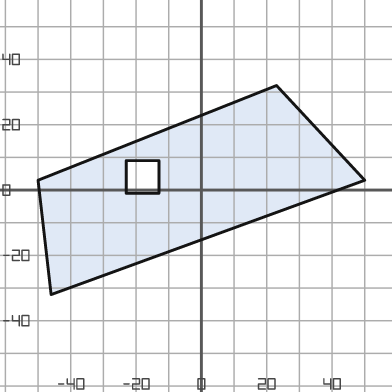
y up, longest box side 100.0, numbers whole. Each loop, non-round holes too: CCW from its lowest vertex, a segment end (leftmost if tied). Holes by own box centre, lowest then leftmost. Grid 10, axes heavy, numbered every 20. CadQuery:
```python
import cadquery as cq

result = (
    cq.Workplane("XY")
    .moveTo(-46.0, -32.0)
    .lineTo(50.0, 3.0)
    .lineTo(23.0, 32.0)
    .lineTo(-50.0, 3.0)
    .close()
    .moveTo(-23.0, -1.0)
    .lineTo(-13.0, -1.0)
    .lineTo(-13.0, 9.0)
    .lineTo(-23.0, 9.0)
    .close()
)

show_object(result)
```